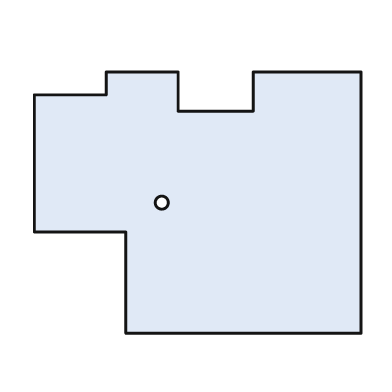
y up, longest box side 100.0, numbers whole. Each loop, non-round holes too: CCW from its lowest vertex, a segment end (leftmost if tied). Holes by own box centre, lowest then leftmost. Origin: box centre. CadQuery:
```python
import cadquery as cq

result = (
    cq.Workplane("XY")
    .moveTo(-22.0, -40.0)
    .lineTo(50.0, -40.0)
    .lineTo(50.0, 40.0)
    .lineTo(17.0, 40.0)
    .lineTo(17.0, 28.0)
    .lineTo(-6.0, 28.0)
    .lineTo(-6.0, 40.0)
    .lineTo(-28.0, 40.0)
    .lineTo(-28.0, 33.0)
    .lineTo(-50.0, 33.0)
    .lineTo(-50.0, -9.0)
    .lineTo(-22.0, -9.0)
    .close()
    .moveTo(-11.0, 0.0)
    .circle(2.0)
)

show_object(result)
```